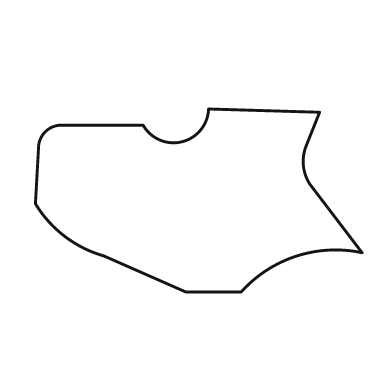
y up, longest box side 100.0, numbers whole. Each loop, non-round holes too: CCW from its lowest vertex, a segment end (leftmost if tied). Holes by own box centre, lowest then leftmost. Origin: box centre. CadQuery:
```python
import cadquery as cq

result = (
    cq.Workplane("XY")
    .moveTo(-4.0, -28.0)
    .lineTo(13.0, -28.0)
    .threePointArc((30.0, -17.0), (50.0, -16.0))
    .lineTo(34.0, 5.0)
    .threePointArc((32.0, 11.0), (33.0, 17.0))
    .lineTo(37.0, 27.0)
    .lineTo(3.0, 28.0)
    .threePointArc((-5.0, 18.0), (-17.0, 23.0))
    .lineTo(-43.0, 23.0)
    .threePointArc((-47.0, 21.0), (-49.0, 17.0))
    .lineTo(-50.0, -1.0)
    .threePointArc((-41.0, -11.0), (-29.0, -17.0))
    .close()
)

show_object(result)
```